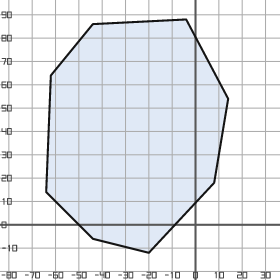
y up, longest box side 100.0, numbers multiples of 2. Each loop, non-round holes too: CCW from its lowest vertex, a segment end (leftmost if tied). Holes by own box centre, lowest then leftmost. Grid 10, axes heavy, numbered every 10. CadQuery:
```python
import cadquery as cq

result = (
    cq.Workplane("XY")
    .moveTo(-20.0, -12.0)
    .lineTo(8.0, 18.0)
    .lineTo(14.0, 54.0)
    .lineTo(-4.0, 88.0)
    .lineTo(-44.0, 86.0)
    .lineTo(-62.0, 64.0)
    .lineTo(-64.0, 14.0)
    .lineTo(-44.0, -6.0)
    .close()
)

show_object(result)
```